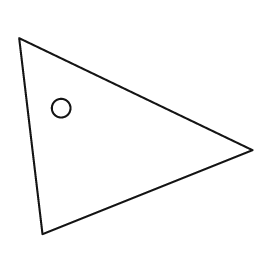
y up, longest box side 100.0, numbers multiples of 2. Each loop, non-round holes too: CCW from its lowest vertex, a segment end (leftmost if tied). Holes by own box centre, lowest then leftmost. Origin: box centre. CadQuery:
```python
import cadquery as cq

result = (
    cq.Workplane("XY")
    .moveTo(-40.0, -42.0)
    .lineTo(50.0, -6.0)
    .lineTo(-50.0, 42.0)
    .close()
    .moveTo(-32.0, 12.0)
    .circle(4.0)
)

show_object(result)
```